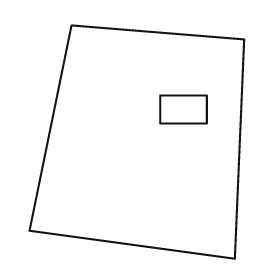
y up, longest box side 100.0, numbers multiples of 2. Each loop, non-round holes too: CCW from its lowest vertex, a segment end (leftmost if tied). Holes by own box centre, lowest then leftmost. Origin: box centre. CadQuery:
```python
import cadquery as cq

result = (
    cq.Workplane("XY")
    .moveTo(42.0, -50.0)
    .lineTo(46.0, 44.0)
    .lineTo(-28.0, 50.0)
    .lineTo(-46.0, -38.0)
    .close()
    .moveTo(10.0, 8.0)
    .lineTo(30.0, 8.0)
    .lineTo(30.0, 20.0)
    .lineTo(10.0, 20.0)
    .close()
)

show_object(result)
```